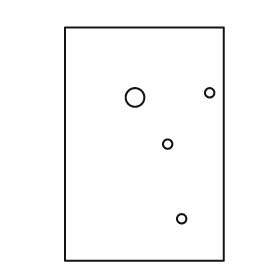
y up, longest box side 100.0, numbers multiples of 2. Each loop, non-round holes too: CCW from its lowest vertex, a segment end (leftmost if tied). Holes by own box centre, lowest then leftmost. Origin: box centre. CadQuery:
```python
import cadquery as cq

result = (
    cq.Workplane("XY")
    .moveTo(-34.0, -50.0)
    .lineTo(34.0, -50.0)
    .lineTo(34.0, 50.0)
    .lineTo(-34.0, 50.0)
    .close()
    .moveTo(16.0, -32.0)
    .circle(2.0)
    .moveTo(10.0, 0.0)
    .circle(2.0)
    .moveTo(-4.0, 20.0)
    .circle(4.0)
    .moveTo(28.0, 22.0)
    .circle(2.0)
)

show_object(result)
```